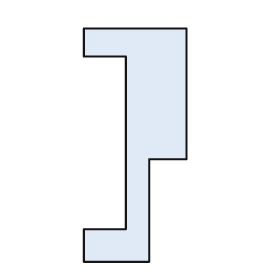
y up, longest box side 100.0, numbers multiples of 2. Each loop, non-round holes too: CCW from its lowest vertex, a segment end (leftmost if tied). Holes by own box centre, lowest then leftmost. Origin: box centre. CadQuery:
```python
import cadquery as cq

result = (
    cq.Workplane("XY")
    .moveTo(-22.0, -50.0)
    .lineTo(6.0, -50.0)
    .lineTo(6.0, -6.0)
    .lineTo(22.0, -6.0)
    .lineTo(22.0, 50.0)
    .lineTo(-22.0, 50.0)
    .lineTo(-22.0, 38.0)
    .lineTo(-4.0, 38.0)
    .lineTo(-4.0, -36.0)
    .lineTo(-22.0, -36.0)
    .close()
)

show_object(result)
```